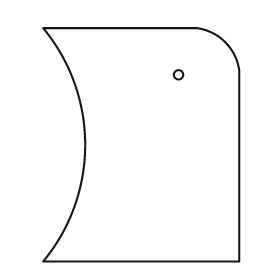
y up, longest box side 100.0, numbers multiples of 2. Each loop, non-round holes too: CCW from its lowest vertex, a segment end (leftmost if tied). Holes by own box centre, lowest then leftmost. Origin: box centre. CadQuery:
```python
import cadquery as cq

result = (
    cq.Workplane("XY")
    .moveTo(-42.0, -50.0)
    .lineTo(42.0, -50.0)
    .lineTo(42.0, 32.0)
    .threePointArc((36.0, 44.0), (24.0, 50.0))
    .lineTo(-42.0, 50.0)
    .threePointArc((-24.0, 0.0), (-42.0, -50.0))
    .close()
    .moveTo(16.0, 30.0)
    .circle(2.0)
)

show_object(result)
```